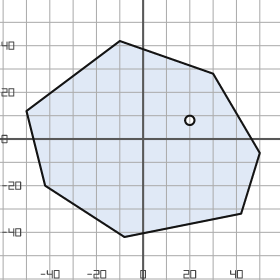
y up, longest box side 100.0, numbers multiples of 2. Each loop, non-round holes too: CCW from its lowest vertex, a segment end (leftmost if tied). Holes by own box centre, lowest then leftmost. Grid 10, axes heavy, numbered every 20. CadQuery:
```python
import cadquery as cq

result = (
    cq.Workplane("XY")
    .moveTo(-8.0, -42.0)
    .lineTo(42.0, -32.0)
    .lineTo(50.0, -6.0)
    .lineTo(30.0, 28.0)
    .lineTo(-10.0, 42.0)
    .lineTo(-50.0, 12.0)
    .lineTo(-42.0, -20.0)
    .close()
    .moveTo(20.0, 8.0)
    .circle(2.0)
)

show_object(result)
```